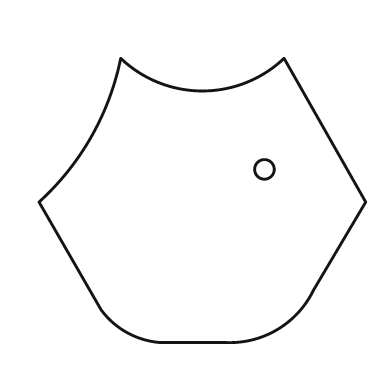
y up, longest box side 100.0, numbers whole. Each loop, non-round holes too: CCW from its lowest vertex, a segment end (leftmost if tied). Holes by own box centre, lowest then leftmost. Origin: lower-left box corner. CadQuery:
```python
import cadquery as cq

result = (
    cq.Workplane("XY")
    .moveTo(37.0, 0.0)
    .lineTo(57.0, 0.0)
    .threePointArc((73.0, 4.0), (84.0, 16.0))
    .lineTo(100.0, 43.0)
    .lineTo(75.0, 87.0)
    .threePointArc((50.0, 77.0), (25.0, 87.0))
    .threePointArc((16.0, 63.0), (0.0, 43.0))
    .lineTo(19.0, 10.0)
    .threePointArc((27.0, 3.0), (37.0, 0.0))
    .close()
    .moveTo(69.0, 53.0)
    .circle(3.0)
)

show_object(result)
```